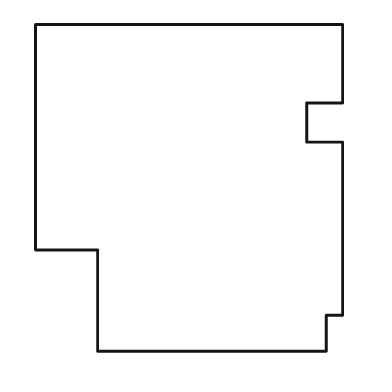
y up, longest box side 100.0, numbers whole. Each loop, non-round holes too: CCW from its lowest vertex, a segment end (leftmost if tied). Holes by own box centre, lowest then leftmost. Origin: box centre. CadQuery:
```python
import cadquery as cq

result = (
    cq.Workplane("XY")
    .moveTo(-28.0, -50.0)
    .lineTo(42.0, -50.0)
    .lineTo(42.0, -39.0)
    .lineTo(47.0, -39.0)
    .lineTo(47.0, 14.0)
    .lineTo(36.0, 14.0)
    .lineTo(36.0, 26.0)
    .lineTo(47.0, 26.0)
    .lineTo(47.0, 50.0)
    .lineTo(-47.0, 50.0)
    .lineTo(-47.0, -19.0)
    .lineTo(-28.0, -19.0)
    .close()
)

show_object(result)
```